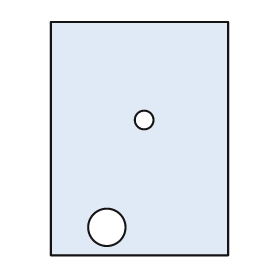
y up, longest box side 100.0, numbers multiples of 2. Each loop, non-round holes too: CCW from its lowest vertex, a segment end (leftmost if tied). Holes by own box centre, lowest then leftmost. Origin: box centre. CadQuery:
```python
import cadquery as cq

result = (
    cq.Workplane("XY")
    .moveTo(-38.0, -50.0)
    .lineTo(38.0, -50.0)
    .lineTo(38.0, 50.0)
    .lineTo(-38.0, 50.0)
    .close()
    .moveTo(-14.0, -38.0)
    .circle(8.0)
    .moveTo(2.0, 8.0)
    .circle(4.0)
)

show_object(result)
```